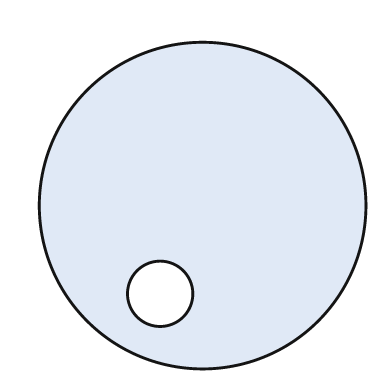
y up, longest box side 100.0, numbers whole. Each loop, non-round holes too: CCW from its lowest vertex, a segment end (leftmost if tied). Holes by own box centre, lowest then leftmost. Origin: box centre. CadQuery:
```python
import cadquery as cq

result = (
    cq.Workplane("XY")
    .moveTo(0.0, 0.0)
    .circle(50.0)
    .moveTo(-13.0, -27.0)
    .circle(10.0)
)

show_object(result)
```